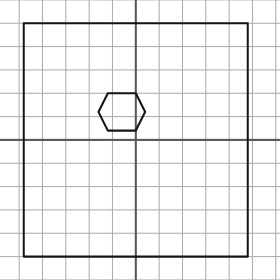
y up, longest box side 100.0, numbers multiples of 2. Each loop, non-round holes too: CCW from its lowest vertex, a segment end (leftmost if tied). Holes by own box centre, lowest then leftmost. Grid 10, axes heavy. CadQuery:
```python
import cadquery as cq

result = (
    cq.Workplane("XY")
    .moveTo(-48.0, -50.0)
    .lineTo(48.0, -50.0)
    .lineTo(48.0, 50.0)
    .lineTo(-48.0, 50.0)
    .close()
    .moveTo(-12.0, 4.0)
    .lineTo(0.0, 4.0)
    .lineTo(4.0, 12.0)
    .lineTo(0.0, 20.0)
    .lineTo(-12.0, 20.0)
    .lineTo(-16.0, 12.0)
    .close()
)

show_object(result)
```